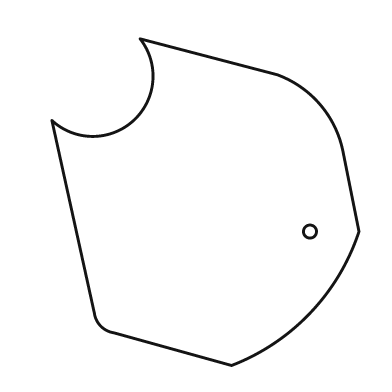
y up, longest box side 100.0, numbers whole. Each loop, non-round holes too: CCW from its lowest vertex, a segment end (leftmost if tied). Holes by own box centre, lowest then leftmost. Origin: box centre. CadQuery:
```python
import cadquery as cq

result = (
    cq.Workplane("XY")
    .moveTo(8.0, -50.0)
    .threePointArc((32.0, -34.0), (47.0, -9.0))
    .lineTo(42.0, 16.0)
    .threePointArc((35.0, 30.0), (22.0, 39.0))
    .lineTo(-20.0, 50.0)
    .threePointArc((-22.0, 25.0), (-47.0, 25.0))
    .lineTo(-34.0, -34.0)
    .threePointArc((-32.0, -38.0), (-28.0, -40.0))
    .close()
    .moveTo(32.0, -9.0)
    .circle(2.0)
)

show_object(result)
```